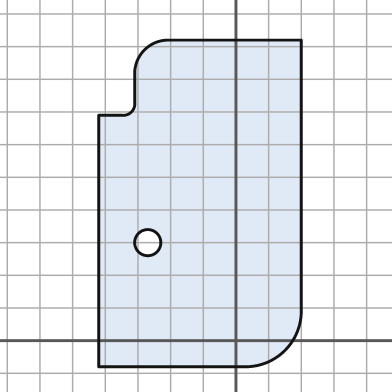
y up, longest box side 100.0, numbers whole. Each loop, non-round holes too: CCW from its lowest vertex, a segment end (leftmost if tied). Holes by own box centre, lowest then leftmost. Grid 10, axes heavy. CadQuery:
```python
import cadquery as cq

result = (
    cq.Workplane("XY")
    .moveTo(-42.0, -8.0)
    .lineTo(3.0, -8.0)
    .threePointArc((15.0, -3.0), (20.0, 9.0))
    .lineTo(20.0, 92.0)
    .lineTo(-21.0, 92.0)
    .threePointArc((-28.0, 89.0), (-31.0, 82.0))
    .lineTo(-31.0, 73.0)
    .threePointArc((-32.0, 70.0), (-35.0, 69.0))
    .lineTo(-42.0, 69.0)
    .close()
    .moveTo(-27.0, 30.0)
    .circle(4.0)
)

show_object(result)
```